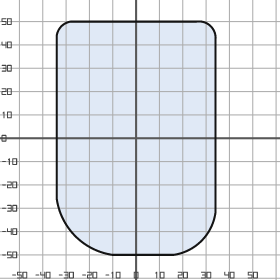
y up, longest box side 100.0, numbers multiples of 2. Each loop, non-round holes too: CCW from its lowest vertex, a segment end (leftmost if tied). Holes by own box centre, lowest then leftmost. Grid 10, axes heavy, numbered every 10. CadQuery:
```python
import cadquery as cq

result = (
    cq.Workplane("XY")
    .moveTo(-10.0, -50.0)
    .lineTo(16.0, -50.0)
    .threePointArc((28.0, -44.0), (34.0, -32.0))
    .lineTo(34.0, 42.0)
    .threePointArc((32.0, 48.0), (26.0, 50.0))
    .lineTo(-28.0, 50.0)
    .threePointArc((-32.0, 48.0), (-34.0, 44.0))
    .lineTo(-34.0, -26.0)
    .threePointArc((-26.0, -42.0), (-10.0, -50.0))
    .close()
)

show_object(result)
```